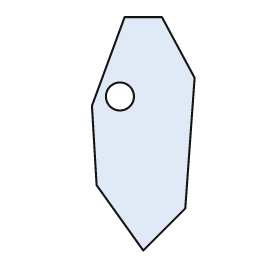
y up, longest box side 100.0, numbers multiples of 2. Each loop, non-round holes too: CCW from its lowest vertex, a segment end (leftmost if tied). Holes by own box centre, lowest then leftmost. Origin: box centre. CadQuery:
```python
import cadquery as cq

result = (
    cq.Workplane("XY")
    .moveTo(0.0, -50.0)
    .lineTo(18.0, -32.0)
    .lineTo(22.0, 24.0)
    .lineTo(8.0, 50.0)
    .lineTo(-8.0, 50.0)
    .lineTo(-22.0, 12.0)
    .lineTo(-20.0, -22.0)
    .close()
    .moveTo(-10.0, 16.0)
    .circle(6.0)
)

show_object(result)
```